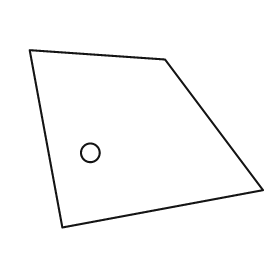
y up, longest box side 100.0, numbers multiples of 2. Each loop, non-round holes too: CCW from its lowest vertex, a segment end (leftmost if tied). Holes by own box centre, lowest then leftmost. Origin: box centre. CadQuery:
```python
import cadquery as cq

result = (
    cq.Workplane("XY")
    .moveTo(-36.0, -38.0)
    .lineTo(50.0, -22.0)
    .lineTo(8.0, 34.0)
    .lineTo(-50.0, 38.0)
    .close()
    .moveTo(-24.0, -6.0)
    .circle(4.0)
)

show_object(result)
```